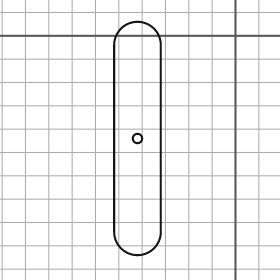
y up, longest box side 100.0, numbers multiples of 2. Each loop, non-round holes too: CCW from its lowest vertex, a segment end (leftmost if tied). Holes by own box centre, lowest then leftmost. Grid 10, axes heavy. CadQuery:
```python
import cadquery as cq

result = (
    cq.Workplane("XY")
    .moveTo(-52.0, -84.0)
    .threePointArc((-42.0, -94.0), (-32.0, -84.0))
    .lineTo(-32.0, -4.0)
    .threePointArc((-42.0, 6.0), (-52.0, -4.0))
    .close()
    .moveTo(-42.0, -44.0)
    .circle(2.0)
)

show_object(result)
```